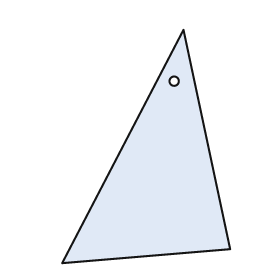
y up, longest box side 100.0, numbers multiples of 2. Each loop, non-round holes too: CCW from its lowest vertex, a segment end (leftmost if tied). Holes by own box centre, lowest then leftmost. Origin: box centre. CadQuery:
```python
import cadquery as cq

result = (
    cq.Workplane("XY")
    .moveTo(-36.0, -50.0)
    .lineTo(36.0, -44.0)
    .lineTo(16.0, 50.0)
    .close()
    .moveTo(12.0, 28.0)
    .circle(2.0)
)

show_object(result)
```